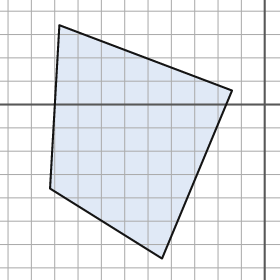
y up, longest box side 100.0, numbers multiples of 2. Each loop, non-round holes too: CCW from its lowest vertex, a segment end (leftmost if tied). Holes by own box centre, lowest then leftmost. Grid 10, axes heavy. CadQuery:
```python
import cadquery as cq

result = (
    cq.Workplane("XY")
    .moveTo(-44.0, -66.0)
    .lineTo(-14.0, 6.0)
    .lineTo(-88.0, 34.0)
    .lineTo(-92.0, -36.0)
    .close()
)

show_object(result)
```